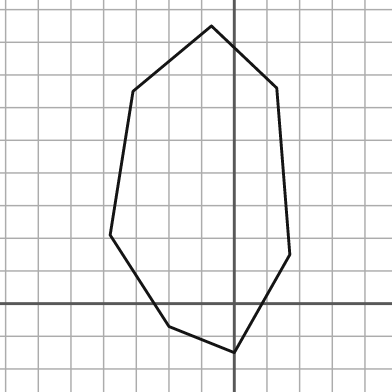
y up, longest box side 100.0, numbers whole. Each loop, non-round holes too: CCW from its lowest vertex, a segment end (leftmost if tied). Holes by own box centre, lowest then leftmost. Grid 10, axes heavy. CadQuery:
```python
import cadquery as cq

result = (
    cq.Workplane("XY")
    .moveTo(0.0, -15.0)
    .lineTo(17.0, 15.0)
    .lineTo(13.0, 66.0)
    .lineTo(-7.0, 85.0)
    .lineTo(-31.0, 65.0)
    .lineTo(-38.0, 21.0)
    .lineTo(-20.0, -7.0)
    .close()
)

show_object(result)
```